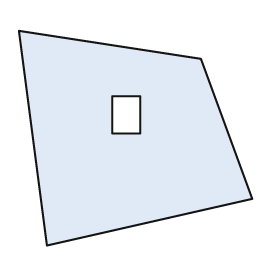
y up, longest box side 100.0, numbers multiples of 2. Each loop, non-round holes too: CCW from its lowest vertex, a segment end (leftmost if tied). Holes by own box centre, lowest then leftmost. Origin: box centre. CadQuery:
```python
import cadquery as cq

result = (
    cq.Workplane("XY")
    .moveTo(-38.0, -46.0)
    .lineTo(50.0, -26.0)
    .lineTo(28.0, 34.0)
    .lineTo(-50.0, 46.0)
    .close()
    .moveTo(-10.0, 2.0)
    .lineTo(2.0, 2.0)
    .lineTo(2.0, 18.0)
    .lineTo(-10.0, 18.0)
    .close()
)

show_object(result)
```